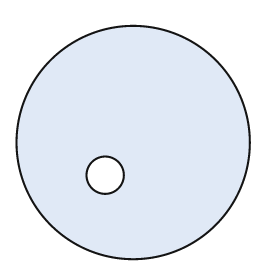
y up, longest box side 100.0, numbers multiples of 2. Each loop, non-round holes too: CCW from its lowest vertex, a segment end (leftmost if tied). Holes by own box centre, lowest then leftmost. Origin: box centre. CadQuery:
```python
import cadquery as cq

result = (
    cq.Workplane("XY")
    .moveTo(0.0, 0.0)
    .circle(50.0)
    .moveTo(-12.0, -14.0)
    .circle(8.0)
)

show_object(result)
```